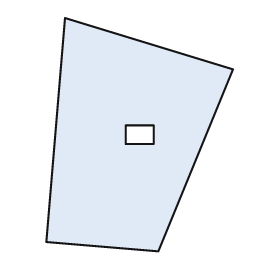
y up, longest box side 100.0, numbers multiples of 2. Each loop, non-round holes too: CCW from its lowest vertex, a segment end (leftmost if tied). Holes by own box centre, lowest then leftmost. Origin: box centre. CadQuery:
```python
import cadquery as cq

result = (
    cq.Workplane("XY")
    .moveTo(8.0, -50.0)
    .lineTo(40.0, 28.0)
    .lineTo(-32.0, 50.0)
    .lineTo(-40.0, -46.0)
    .close()
    .moveTo(-6.0, -4.0)
    .lineTo(6.0, -4.0)
    .lineTo(6.0, 4.0)
    .lineTo(-6.0, 4.0)
    .close()
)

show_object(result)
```